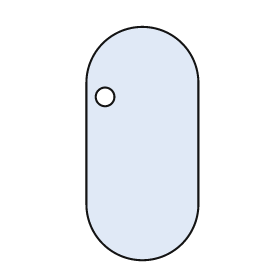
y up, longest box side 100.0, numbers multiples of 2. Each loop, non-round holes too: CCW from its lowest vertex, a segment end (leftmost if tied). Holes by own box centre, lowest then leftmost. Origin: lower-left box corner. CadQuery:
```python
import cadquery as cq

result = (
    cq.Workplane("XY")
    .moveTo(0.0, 24.0)
    .threePointArc((24.0, 0.0), (48.0, 24.0))
    .lineTo(48.0, 76.0)
    .threePointArc((24.0, 100.0), (0.0, 76.0))
    .close()
    .moveTo(8.0, 70.0)
    .circle(4.0)
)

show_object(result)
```